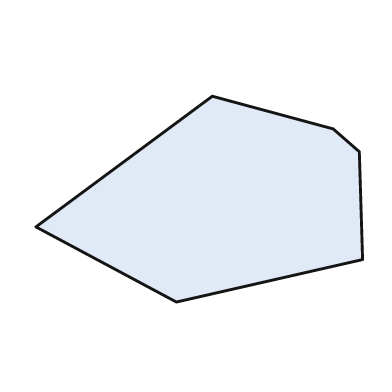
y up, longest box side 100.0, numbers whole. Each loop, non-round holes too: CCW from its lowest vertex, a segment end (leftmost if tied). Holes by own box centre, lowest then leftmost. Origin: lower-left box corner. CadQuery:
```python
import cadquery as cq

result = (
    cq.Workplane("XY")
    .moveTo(43.0, 0.0)
    .lineTo(100.0, 13.0)
    .lineTo(99.0, 46.0)
    .lineTo(91.0, 53.0)
    .lineTo(54.0, 63.0)
    .lineTo(0.0, 23.0)
    .close()
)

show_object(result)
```